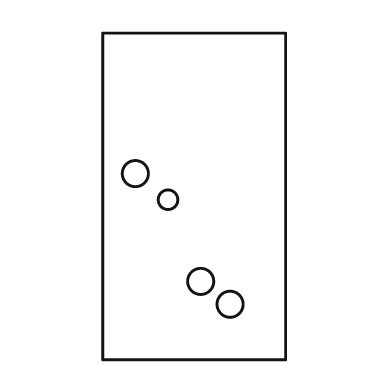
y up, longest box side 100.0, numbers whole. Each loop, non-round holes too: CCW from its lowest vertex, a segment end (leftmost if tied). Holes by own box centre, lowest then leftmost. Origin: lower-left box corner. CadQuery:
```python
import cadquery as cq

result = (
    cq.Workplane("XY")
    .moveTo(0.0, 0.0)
    .lineTo(56.0, 0.0)
    .lineTo(56.0, 100.0)
    .lineTo(0.0, 100.0)
    .close()
    .moveTo(39.0, 17.0)
    .circle(4.0)
    .moveTo(30.0, 24.0)
    .circle(4.0)
    .moveTo(20.0, 49.0)
    .circle(3.0)
    .moveTo(10.0, 57.0)
    .circle(4.0)
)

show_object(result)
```